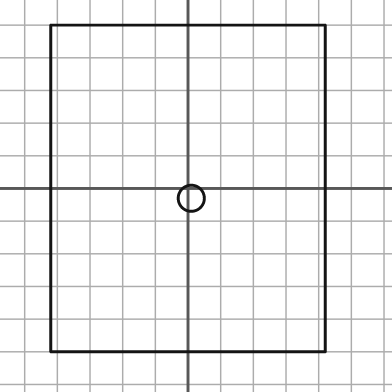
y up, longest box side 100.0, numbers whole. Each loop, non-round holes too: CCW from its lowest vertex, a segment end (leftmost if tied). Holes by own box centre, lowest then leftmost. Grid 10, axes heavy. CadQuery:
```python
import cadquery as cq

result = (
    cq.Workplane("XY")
    .moveTo(-42.0, -50.0)
    .lineTo(42.0, -50.0)
    .lineTo(42.0, 50.0)
    .lineTo(-42.0, 50.0)
    .close()
    .moveTo(1.0, -3.0)
    .circle(4.0)
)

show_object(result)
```